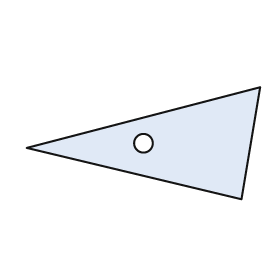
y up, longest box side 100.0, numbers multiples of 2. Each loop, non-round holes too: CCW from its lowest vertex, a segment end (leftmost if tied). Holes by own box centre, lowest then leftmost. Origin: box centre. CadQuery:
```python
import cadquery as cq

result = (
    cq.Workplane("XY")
    .moveTo(42.0, -24.0)
    .lineTo(50.0, 24.0)
    .lineTo(-50.0, -2.0)
    .close()
    .moveTo(0.0, 0.0)
    .circle(4.0)
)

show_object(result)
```